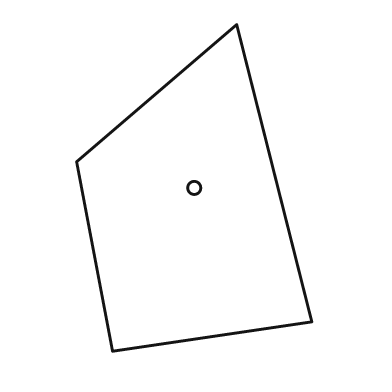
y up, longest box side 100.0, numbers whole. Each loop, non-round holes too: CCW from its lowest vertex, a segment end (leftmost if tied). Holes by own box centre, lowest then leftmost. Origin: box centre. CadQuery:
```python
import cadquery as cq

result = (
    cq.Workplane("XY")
    .moveTo(-25.0, -50.0)
    .lineTo(36.0, -41.0)
    .lineTo(13.0, 50.0)
    .lineTo(-36.0, 8.0)
    .close()
    .moveTo(0.0, 0.0)
    .circle(2.0)
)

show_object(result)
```